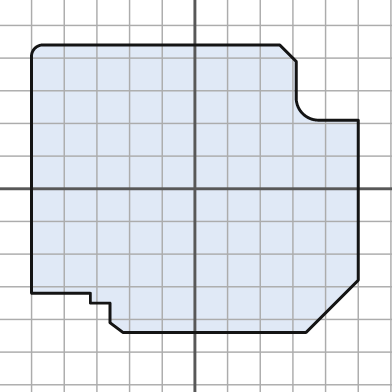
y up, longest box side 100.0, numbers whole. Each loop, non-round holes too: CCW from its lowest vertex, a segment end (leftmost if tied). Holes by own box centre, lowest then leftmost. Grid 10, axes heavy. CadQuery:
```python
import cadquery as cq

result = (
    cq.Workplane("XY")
    .moveTo(-22.0, -44.0)
    .lineTo(34.0, -44.0)
    .lineTo(50.0, -28.0)
    .lineTo(50.0, 21.0)
    .lineTo(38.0, 21.0)
    .threePointArc((33.0, 23.0), (31.0, 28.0))
    .lineTo(31.0, 39.0)
    .lineTo(26.0, 44.0)
    .lineTo(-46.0, 44.0)
    .threePointArc((-49.0, 43.0), (-50.0, 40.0))
    .lineTo(-50.0, -32.0)
    .lineTo(-32.0, -32.0)
    .lineTo(-32.0, -35.0)
    .lineTo(-26.0, -35.0)
    .lineTo(-26.0, -41.0)
    .close()
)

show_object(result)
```